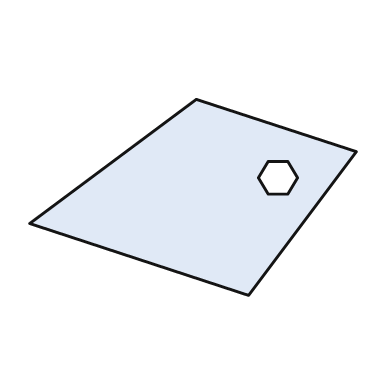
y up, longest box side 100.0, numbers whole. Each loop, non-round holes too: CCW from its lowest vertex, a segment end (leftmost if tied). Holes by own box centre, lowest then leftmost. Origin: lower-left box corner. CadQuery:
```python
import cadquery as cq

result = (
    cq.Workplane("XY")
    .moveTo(67.0, 0.0)
    .lineTo(100.0, 44.0)
    .lineTo(51.0, 60.0)
    .lineTo(0.0, 22.0)
    .close()
    .moveTo(73.0, 31.0)
    .lineTo(79.0, 31.0)
    .lineTo(82.0, 36.0)
    .lineTo(79.0, 41.0)
    .lineTo(73.0, 41.0)
    .lineTo(70.0, 36.0)
    .close()
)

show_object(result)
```